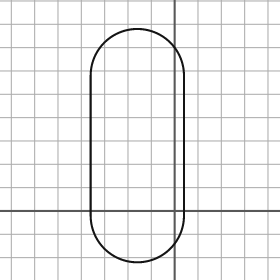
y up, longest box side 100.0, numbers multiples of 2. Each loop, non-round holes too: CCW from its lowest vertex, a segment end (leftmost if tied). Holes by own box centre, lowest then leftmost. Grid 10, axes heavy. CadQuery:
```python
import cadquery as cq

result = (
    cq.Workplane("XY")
    .moveTo(-36.0, -2.0)
    .threePointArc((-16.0, -22.0), (4.0, -2.0))
    .lineTo(4.0, 58.0)
    .threePointArc((-16.0, 78.0), (-36.0, 58.0))
    .close()
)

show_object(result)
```